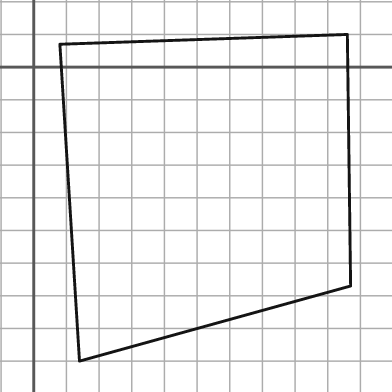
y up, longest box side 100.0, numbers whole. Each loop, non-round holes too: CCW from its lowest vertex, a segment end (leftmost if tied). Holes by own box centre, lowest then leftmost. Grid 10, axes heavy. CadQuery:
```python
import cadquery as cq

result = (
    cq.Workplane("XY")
    .moveTo(14.0, -90.0)
    .lineTo(97.0, -67.0)
    .lineTo(96.0, 10.0)
    .lineTo(8.0, 7.0)
    .close()
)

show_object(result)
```